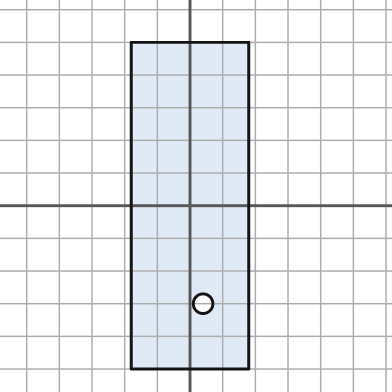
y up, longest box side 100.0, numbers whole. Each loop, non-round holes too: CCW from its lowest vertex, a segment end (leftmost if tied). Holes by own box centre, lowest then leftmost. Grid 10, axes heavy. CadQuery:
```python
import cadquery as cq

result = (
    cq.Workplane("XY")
    .moveTo(-18.0, -50.0)
    .lineTo(18.0, -50.0)
    .lineTo(18.0, 50.0)
    .lineTo(-18.0, 50.0)
    .close()
    .moveTo(4.0, -30.0)
    .circle(3.0)
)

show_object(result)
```